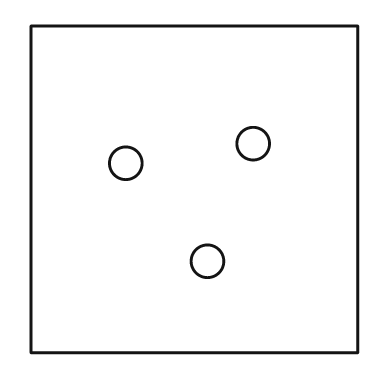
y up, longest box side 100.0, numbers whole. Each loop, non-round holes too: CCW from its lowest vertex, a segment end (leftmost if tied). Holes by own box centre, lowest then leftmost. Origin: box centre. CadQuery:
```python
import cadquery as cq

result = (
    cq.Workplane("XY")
    .moveTo(-50.0, -50.0)
    .lineTo(50.0, -50.0)
    .lineTo(50.0, 50.0)
    .lineTo(-50.0, 50.0)
    .close()
    .moveTo(4.0, -22.0)
    .circle(5.0)
    .moveTo(-21.0, 8.0)
    .circle(5.0)
    .moveTo(18.0, 14.0)
    .circle(5.0)
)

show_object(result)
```